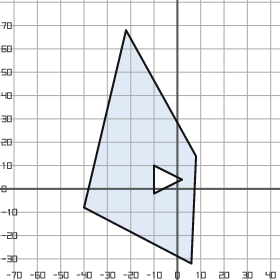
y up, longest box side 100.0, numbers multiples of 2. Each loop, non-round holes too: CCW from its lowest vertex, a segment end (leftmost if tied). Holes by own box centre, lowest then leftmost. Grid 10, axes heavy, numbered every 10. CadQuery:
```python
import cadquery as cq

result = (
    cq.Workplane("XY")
    .moveTo(6.0, -32.0)
    .lineTo(8.0, 14.0)
    .lineTo(-22.0, 68.0)
    .lineTo(-40.0, -8.0)
    .close()
    .moveTo(-10.0, -2.0)
    .lineTo(2.0, 4.0)
    .lineTo(-10.0, 10.0)
    .close()
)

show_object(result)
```